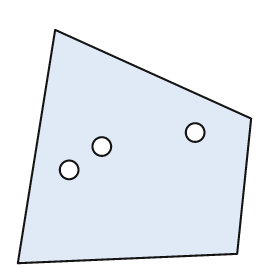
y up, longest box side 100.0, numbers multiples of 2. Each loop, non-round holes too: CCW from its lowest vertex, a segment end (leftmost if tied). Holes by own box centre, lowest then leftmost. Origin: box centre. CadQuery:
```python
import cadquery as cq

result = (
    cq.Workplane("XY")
    .moveTo(-50.0, -50.0)
    .lineTo(44.0, -46.0)
    .lineTo(50.0, 12.0)
    .lineTo(-34.0, 50.0)
    .close()
    .moveTo(-28.0, -10.0)
    .circle(4.0)
    .moveTo(-14.0, 0.0)
    .circle(4.0)
    .moveTo(26.0, 6.0)
    .circle(4.0)
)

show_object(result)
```